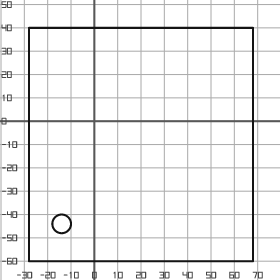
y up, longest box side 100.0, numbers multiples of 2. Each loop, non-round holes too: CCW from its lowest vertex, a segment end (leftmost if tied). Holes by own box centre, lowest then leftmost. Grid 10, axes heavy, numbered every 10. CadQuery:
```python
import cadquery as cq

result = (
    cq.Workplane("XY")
    .moveTo(-28.0, -60.0)
    .lineTo(68.0, -60.0)
    .lineTo(68.0, 40.0)
    .lineTo(-28.0, 40.0)
    .close()
    .moveTo(-14.0, -44.0)
    .circle(4.0)
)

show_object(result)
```